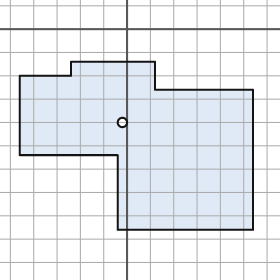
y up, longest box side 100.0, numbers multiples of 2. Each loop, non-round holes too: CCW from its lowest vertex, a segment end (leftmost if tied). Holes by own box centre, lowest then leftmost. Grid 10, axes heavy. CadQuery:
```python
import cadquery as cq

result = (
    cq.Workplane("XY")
    .moveTo(-4.0, -86.0)
    .lineTo(54.0, -86.0)
    .lineTo(54.0, -26.0)
    .lineTo(12.0, -26.0)
    .lineTo(12.0, -14.0)
    .lineTo(-24.0, -14.0)
    .lineTo(-24.0, -20.0)
    .lineTo(-46.0, -20.0)
    .lineTo(-46.0, -54.0)
    .lineTo(-4.0, -54.0)
    .close()
    .moveTo(-2.0, -40.0)
    .circle(2.0)
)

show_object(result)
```